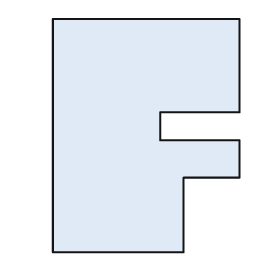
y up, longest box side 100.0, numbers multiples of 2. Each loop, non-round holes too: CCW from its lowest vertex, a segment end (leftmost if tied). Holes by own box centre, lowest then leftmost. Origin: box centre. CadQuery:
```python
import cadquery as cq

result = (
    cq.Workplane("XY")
    .moveTo(-40.0, -50.0)
    .lineTo(16.0, -50.0)
    .lineTo(16.0, -18.0)
    .lineTo(40.0, -18.0)
    .lineTo(40.0, -2.0)
    .lineTo(6.0, -2.0)
    .lineTo(6.0, 10.0)
    .lineTo(40.0, 10.0)
    .lineTo(40.0, 50.0)
    .lineTo(-40.0, 50.0)
    .close()
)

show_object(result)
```